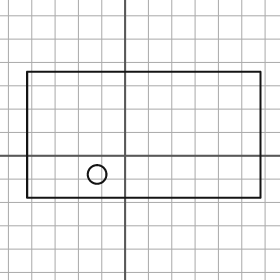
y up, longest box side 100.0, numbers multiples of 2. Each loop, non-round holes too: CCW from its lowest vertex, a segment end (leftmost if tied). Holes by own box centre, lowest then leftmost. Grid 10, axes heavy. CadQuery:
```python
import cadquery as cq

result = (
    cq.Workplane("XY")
    .moveTo(-42.0, -18.0)
    .lineTo(58.0, -18.0)
    .lineTo(58.0, 36.0)
    .lineTo(-42.0, 36.0)
    .close()
    .moveTo(-12.0, -8.0)
    .circle(4.0)
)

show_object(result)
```